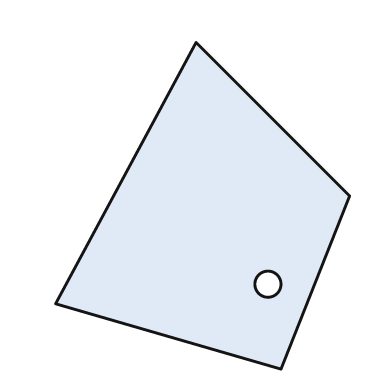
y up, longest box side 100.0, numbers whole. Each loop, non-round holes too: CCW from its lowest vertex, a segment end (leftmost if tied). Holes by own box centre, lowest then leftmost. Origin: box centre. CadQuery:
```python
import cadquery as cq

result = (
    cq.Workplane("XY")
    .moveTo(24.0, -50.0)
    .lineTo(45.0, 3.0)
    .lineTo(-2.0, 50.0)
    .lineTo(-45.0, -30.0)
    .close()
    .moveTo(20.0, -24.0)
    .circle(4.0)
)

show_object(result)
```